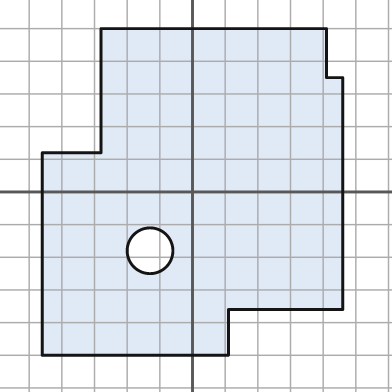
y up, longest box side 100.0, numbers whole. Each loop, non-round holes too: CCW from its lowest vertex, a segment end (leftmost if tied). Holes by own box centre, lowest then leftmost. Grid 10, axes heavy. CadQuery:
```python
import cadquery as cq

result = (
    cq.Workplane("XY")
    .moveTo(-46.0, -50.0)
    .lineTo(11.0, -50.0)
    .lineTo(11.0, -36.0)
    .lineTo(46.0, -36.0)
    .lineTo(46.0, 35.0)
    .lineTo(41.0, 35.0)
    .lineTo(41.0, 50.0)
    .lineTo(-28.0, 50.0)
    .lineTo(-28.0, 12.0)
    .lineTo(-46.0, 12.0)
    .close()
    .moveTo(-13.0, -18.0)
    .circle(7.0)
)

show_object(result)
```